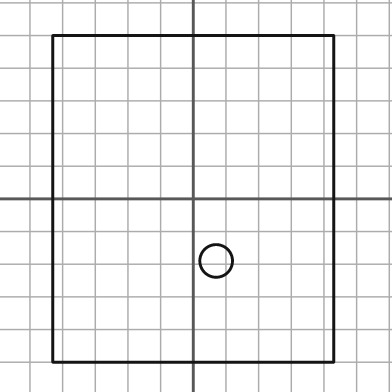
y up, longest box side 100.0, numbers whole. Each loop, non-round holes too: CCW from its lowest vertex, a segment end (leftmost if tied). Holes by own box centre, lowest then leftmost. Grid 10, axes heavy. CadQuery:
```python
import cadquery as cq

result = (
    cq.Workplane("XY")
    .moveTo(-43.0, -50.0)
    .lineTo(43.0, -50.0)
    .lineTo(43.0, 50.0)
    .lineTo(-43.0, 50.0)
    .close()
    .moveTo(7.0, -19.0)
    .circle(5.0)
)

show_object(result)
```